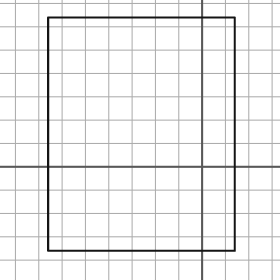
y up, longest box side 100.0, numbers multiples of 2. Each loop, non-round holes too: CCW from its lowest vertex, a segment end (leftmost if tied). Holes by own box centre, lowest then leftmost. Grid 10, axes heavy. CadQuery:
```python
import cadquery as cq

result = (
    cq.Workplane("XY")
    .moveTo(-66.0, -36.0)
    .lineTo(14.0, -36.0)
    .lineTo(14.0, 64.0)
    .lineTo(-66.0, 64.0)
    .close()
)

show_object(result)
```